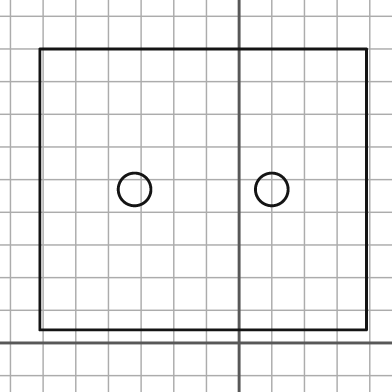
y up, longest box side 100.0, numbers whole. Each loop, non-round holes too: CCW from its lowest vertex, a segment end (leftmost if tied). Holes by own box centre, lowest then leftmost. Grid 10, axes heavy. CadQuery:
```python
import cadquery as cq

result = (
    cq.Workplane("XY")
    .moveTo(-61.0, 4.0)
    .lineTo(39.0, 4.0)
    .lineTo(39.0, 90.0)
    .lineTo(-61.0, 90.0)
    .close()
    .moveTo(-32.0, 47.0)
    .circle(5.0)
    .moveTo(10.0, 47.0)
    .circle(5.0)
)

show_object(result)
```